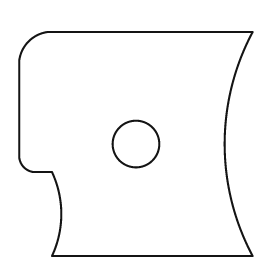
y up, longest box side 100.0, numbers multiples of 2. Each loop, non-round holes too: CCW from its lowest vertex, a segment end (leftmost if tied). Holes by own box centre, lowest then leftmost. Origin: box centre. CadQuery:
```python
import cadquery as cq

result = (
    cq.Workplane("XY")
    .moveTo(-36.0, -48.0)
    .lineTo(50.0, -48.0)
    .threePointArc((38.0, 0.0), (50.0, 48.0))
    .lineTo(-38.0, 48.0)
    .threePointArc((-46.0, 44.0), (-50.0, 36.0))
    .lineTo(-50.0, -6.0)
    .threePointArc((-48.0, -10.0), (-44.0, -12.0))
    .lineTo(-36.0, -12.0)
    .threePointArc((-32.0, -30.0), (-36.0, -48.0))
    .close()
    .moveTo(0.0, 0.0)
    .circle(10.0)
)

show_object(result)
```